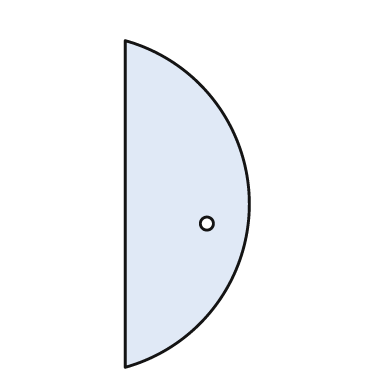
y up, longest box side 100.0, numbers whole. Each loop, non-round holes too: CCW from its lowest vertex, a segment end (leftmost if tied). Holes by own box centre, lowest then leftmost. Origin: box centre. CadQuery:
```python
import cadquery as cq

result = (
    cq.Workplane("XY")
    .moveTo(-19.0, -50.0)
    .threePointArc((19.0, 0.0), (-19.0, 50.0))
    .close()
    .moveTo(6.0, -6.0)
    .circle(2.0)
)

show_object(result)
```